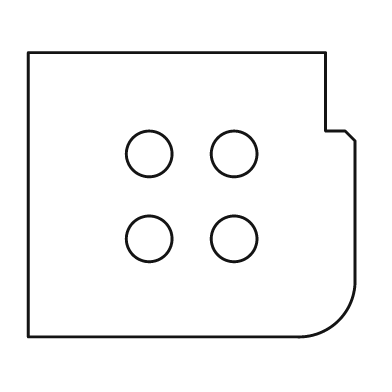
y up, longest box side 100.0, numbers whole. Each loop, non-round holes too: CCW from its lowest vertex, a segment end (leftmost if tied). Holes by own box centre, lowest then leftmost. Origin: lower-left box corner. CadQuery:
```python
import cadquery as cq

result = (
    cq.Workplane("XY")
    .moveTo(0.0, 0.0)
    .lineTo(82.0, 0.0)
    .threePointArc((95.0, 5.0), (100.0, 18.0))
    .lineTo(100.0, 60.0)
    .lineTo(97.0, 63.0)
    .lineTo(91.0, 63.0)
    .lineTo(91.0, 87.0)
    .lineTo(0.0, 87.0)
    .close()
    .moveTo(37.0, 30.0)
    .circle(7.0)
    .moveTo(63.0, 30.0)
    .circle(7.0)
    .moveTo(37.0, 56.0)
    .circle(7.0)
    .moveTo(63.0, 56.0)
    .circle(7.0)
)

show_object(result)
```